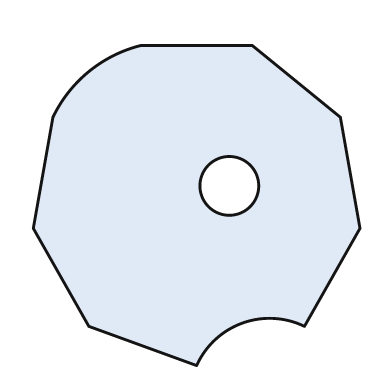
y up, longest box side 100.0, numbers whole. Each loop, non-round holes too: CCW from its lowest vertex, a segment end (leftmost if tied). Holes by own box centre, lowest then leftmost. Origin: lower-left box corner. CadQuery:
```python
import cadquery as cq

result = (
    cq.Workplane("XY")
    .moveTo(50.0, 0.0)
    .threePointArc((64.0, 13.0), (83.0, 12.0))
    .lineTo(100.0, 42.0)
    .lineTo(94.0, 76.0)
    .lineTo(67.0, 98.0)
    .lineTo(33.0, 98.0)
    .threePointArc((17.0, 90.0), (6.0, 76.0))
    .lineTo(0.0, 42.0)
    .lineTo(17.0, 12.0)
    .close()
    .moveTo(60.0, 55.0)
    .circle(9.0)
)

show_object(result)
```